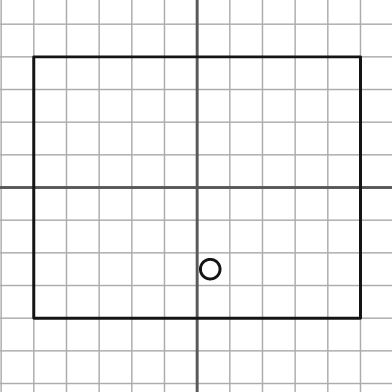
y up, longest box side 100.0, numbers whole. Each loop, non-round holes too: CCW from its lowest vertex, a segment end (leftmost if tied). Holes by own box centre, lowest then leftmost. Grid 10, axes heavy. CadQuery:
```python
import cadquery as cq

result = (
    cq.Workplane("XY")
    .moveTo(-50.0, -40.0)
    .lineTo(50.0, -40.0)
    .lineTo(50.0, 40.0)
    .lineTo(-50.0, 40.0)
    .close()
    .moveTo(4.0, -25.0)
    .circle(3.0)
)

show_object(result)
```